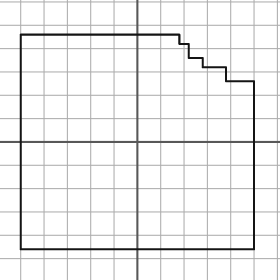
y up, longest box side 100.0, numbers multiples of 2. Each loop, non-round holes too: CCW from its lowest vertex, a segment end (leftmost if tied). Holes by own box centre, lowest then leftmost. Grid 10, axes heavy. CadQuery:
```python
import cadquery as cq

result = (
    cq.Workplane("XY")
    .moveTo(-50.0, -46.0)
    .lineTo(50.0, -46.0)
    .lineTo(50.0, 26.0)
    .lineTo(38.0, 26.0)
    .lineTo(38.0, 32.0)
    .lineTo(28.0, 32.0)
    .lineTo(28.0, 36.0)
    .lineTo(22.0, 36.0)
    .lineTo(22.0, 42.0)
    .lineTo(18.0, 42.0)
    .lineTo(18.0, 46.0)
    .lineTo(-50.0, 46.0)
    .close()
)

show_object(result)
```